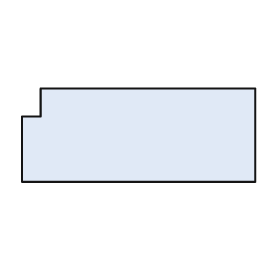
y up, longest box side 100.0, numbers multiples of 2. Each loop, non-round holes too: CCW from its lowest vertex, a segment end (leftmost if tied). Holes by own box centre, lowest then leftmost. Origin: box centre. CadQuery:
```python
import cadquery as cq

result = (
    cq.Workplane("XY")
    .moveTo(-50.0, -20.0)
    .lineTo(50.0, -20.0)
    .lineTo(50.0, 20.0)
    .lineTo(-42.0, 20.0)
    .lineTo(-42.0, 8.0)
    .lineTo(-50.0, 8.0)
    .close()
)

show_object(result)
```